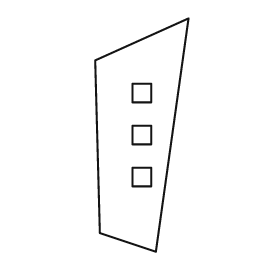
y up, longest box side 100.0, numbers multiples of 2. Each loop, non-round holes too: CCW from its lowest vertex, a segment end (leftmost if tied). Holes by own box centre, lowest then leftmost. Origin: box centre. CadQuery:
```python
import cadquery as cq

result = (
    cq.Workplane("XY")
    .moveTo(6.0, -50.0)
    .lineTo(20.0, 50.0)
    .lineTo(-20.0, 32.0)
    .lineTo(-18.0, -42.0)
    .close()
    .moveTo(-4.0, -22.0)
    .lineTo(4.0, -22.0)
    .lineTo(4.0, -14.0)
    .lineTo(-4.0, -14.0)
    .close()
    .moveTo(-4.0, -4.0)
    .lineTo(4.0, -4.0)
    .lineTo(4.0, 4.0)
    .lineTo(-4.0, 4.0)
    .close()
    .moveTo(-4.0, 14.0)
    .lineTo(4.0, 14.0)
    .lineTo(4.0, 22.0)
    .lineTo(-4.0, 22.0)
    .close()
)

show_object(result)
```